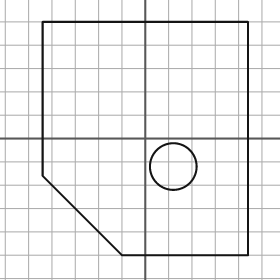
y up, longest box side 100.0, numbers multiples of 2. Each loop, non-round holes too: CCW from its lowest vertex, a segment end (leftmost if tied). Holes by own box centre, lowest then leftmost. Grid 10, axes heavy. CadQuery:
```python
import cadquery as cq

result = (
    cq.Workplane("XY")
    .moveTo(-10.0, -50.0)
    .lineTo(44.0, -50.0)
    .lineTo(44.0, 50.0)
    .lineTo(-44.0, 50.0)
    .lineTo(-44.0, -16.0)
    .close()
    .moveTo(12.0, -12.0)
    .circle(10.0)
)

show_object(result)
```